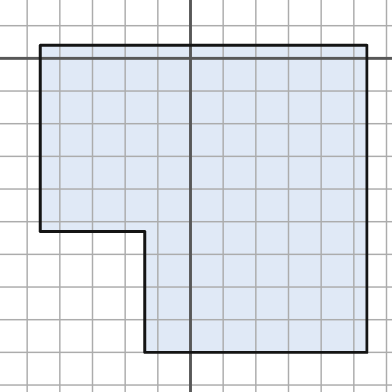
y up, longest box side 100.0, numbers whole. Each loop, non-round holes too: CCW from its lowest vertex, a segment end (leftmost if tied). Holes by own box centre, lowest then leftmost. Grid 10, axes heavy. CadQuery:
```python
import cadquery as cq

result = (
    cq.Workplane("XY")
    .moveTo(-14.0, -90.0)
    .lineTo(54.0, -90.0)
    .lineTo(54.0, 4.0)
    .lineTo(-46.0, 4.0)
    .lineTo(-46.0, -53.0)
    .lineTo(-14.0, -53.0)
    .close()
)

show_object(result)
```